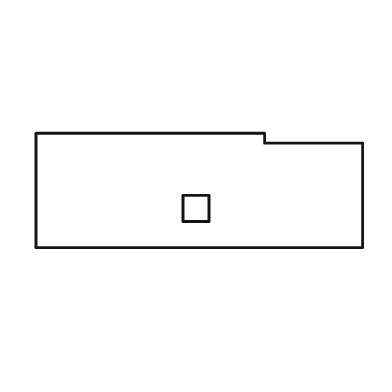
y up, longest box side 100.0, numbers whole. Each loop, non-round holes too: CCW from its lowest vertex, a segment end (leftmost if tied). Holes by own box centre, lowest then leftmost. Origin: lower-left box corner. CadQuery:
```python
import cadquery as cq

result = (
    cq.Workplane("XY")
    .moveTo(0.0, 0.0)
    .lineTo(100.0, 0.0)
    .lineTo(100.0, 32.0)
    .lineTo(70.0, 32.0)
    .lineTo(70.0, 35.0)
    .lineTo(0.0, 35.0)
    .close()
    .moveTo(45.0, 8.0)
    .lineTo(53.0, 8.0)
    .lineTo(53.0, 16.0)
    .lineTo(45.0, 16.0)
    .close()
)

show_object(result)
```